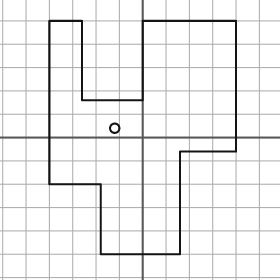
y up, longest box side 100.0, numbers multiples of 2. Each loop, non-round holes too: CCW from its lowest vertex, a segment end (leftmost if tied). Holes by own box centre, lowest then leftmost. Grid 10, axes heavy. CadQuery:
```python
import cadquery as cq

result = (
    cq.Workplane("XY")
    .moveTo(-18.0, -50.0)
    .lineTo(16.0, -50.0)
    .lineTo(16.0, -6.0)
    .lineTo(40.0, -6.0)
    .lineTo(40.0, 50.0)
    .lineTo(0.0, 50.0)
    .lineTo(0.0, 16.0)
    .lineTo(-26.0, 16.0)
    .lineTo(-26.0, 50.0)
    .lineTo(-40.0, 50.0)
    .lineTo(-40.0, -20.0)
    .lineTo(-18.0, -20.0)
    .close()
    .moveTo(-12.0, 4.0)
    .circle(2.0)
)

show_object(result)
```